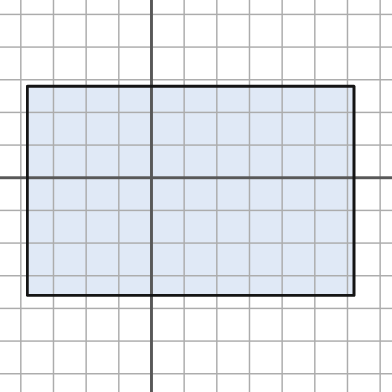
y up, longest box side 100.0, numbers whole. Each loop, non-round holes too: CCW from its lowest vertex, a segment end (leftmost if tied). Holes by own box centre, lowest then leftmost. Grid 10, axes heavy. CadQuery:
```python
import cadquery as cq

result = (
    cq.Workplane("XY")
    .moveTo(-38.0, -36.0)
    .lineTo(62.0, -36.0)
    .lineTo(62.0, 28.0)
    .lineTo(-38.0, 28.0)
    .close()
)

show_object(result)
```